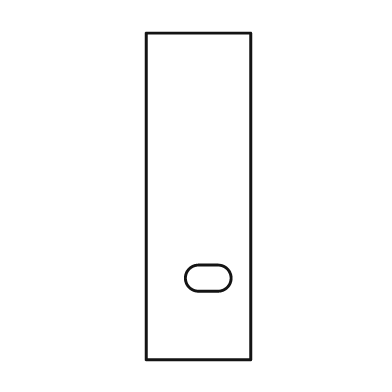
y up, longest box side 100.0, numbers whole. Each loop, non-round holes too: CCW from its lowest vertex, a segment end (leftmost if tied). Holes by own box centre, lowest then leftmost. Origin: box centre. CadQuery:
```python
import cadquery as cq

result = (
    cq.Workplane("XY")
    .moveTo(-16.0, -50.0)
    .lineTo(16.0, -50.0)
    .lineTo(16.0, 50.0)
    .lineTo(-16.0, 50.0)
    .close()
    .moveTo(0.0, -29.0)
    .lineTo(6.0, -29.0)
    .threePointArc((10.0, -25.0), (6.0, -21.0))
    .lineTo(0.0, -21.0)
    .threePointArc((-4.0, -25.0), (0.0, -29.0))
    .close()
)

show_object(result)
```